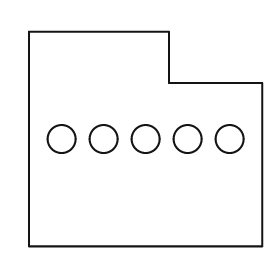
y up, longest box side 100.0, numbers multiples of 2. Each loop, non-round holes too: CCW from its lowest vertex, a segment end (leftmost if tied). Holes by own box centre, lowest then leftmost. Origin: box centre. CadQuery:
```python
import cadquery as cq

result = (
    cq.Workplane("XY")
    .moveTo(-50.0, -46.0)
    .lineTo(50.0, -46.0)
    .lineTo(50.0, 24.0)
    .lineTo(10.0, 24.0)
    .lineTo(10.0, 46.0)
    .lineTo(-50.0, 46.0)
    .close()
    .moveTo(-36.0, 0.0)
    .circle(6.0)
    .moveTo(-18.0, 0.0)
    .circle(6.0)
    .moveTo(0.0, 0.0)
    .circle(6.0)
    .moveTo(18.0, 0.0)
    .circle(6.0)
    .moveTo(36.0, 0.0)
    .circle(6.0)
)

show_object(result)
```